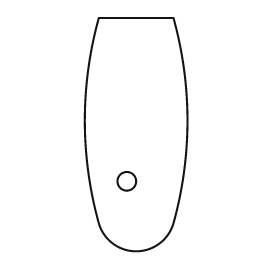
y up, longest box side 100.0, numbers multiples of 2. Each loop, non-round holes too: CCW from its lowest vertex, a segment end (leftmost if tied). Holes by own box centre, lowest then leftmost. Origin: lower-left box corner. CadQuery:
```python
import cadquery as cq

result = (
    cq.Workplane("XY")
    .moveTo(6.0, 12.0)
    .threePointArc((22.0, 0.0), (38.0, 12.0))
    .threePointArc((44.0, 56.0), (38.0, 100.0))
    .lineTo(6.0, 100.0)
    .threePointArc((0.0, 56.0), (6.0, 12.0))
    .close()
    .moveTo(18.0, 30.0)
    .circle(4.0)
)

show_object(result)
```